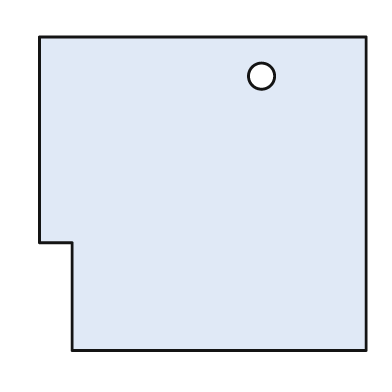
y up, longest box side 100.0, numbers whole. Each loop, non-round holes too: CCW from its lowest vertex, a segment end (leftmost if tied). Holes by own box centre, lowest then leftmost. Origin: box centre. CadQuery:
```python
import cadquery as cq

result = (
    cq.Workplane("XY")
    .moveTo(-40.0, -48.0)
    .lineTo(50.0, -48.0)
    .lineTo(50.0, 48.0)
    .lineTo(-50.0, 48.0)
    .lineTo(-50.0, -15.0)
    .lineTo(-40.0, -15.0)
    .close()
    .moveTo(18.0, 36.0)
    .circle(4.0)
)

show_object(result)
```